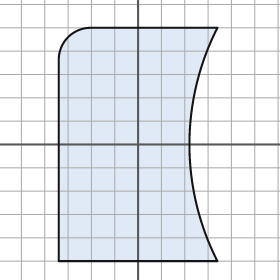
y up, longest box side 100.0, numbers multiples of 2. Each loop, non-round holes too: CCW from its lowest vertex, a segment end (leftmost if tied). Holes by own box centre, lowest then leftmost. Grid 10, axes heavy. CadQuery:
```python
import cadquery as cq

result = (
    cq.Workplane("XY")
    .moveTo(-34.0, -50.0)
    .lineTo(34.0, -50.0)
    .threePointArc((22.0, 0.0), (34.0, 50.0))
    .lineTo(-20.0, 50.0)
    .threePointArc((-30.0, 46.0), (-34.0, 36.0))
    .close()
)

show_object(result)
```